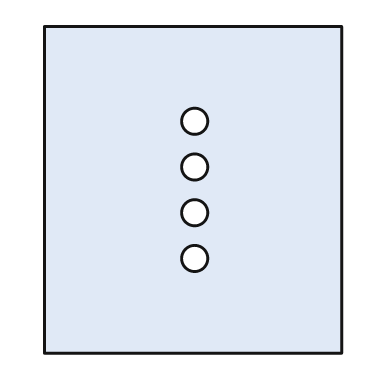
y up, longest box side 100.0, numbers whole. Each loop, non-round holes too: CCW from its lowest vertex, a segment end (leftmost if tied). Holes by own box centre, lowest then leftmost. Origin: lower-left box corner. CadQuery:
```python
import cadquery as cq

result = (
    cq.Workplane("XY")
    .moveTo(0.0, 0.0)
    .lineTo(91.0, 0.0)
    .lineTo(91.0, 100.0)
    .lineTo(0.0, 100.0)
    .close()
    .moveTo(46.0, 29.0)
    .circle(4.0)
    .moveTo(46.0, 43.0)
    .circle(4.0)
    .moveTo(46.0, 57.0)
    .circle(4.0)
    .moveTo(46.0, 71.0)
    .circle(4.0)
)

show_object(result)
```